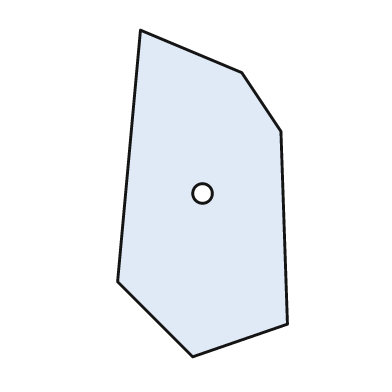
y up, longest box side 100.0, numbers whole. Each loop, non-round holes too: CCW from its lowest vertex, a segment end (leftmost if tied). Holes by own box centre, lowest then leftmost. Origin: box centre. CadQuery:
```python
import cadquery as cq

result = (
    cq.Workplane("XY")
    .moveTo(-3.0, -50.0)
    .lineTo(26.0, -40.0)
    .lineTo(24.0, 19.0)
    .lineTo(12.0, 37.0)
    .lineTo(-19.0, 50.0)
    .lineTo(-26.0, -27.0)
    .close()
    .moveTo(0.0, 0.0)
    .circle(3.0)
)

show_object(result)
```